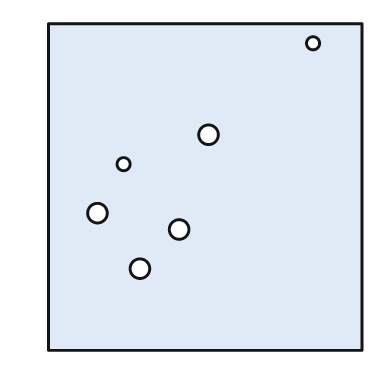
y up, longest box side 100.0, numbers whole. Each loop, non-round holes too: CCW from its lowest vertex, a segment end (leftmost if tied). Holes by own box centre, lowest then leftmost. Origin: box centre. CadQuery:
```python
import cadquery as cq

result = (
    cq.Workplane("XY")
    .moveTo(-48.0, -50.0)
    .lineTo(48.0, -50.0)
    .lineTo(48.0, 50.0)
    .lineTo(-48.0, 50.0)
    .close()
    .moveTo(-20.0, -25.0)
    .circle(3.0)
    .moveTo(-8.0, -13.0)
    .circle(3.0)
    .moveTo(-33.0, -8.0)
    .circle(3.0)
    .moveTo(-25.0, 7.0)
    .circle(2.0)
    .moveTo(1.0, 16.0)
    .circle(3.0)
    .moveTo(33.0, 44.0)
    .circle(2.0)
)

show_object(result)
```